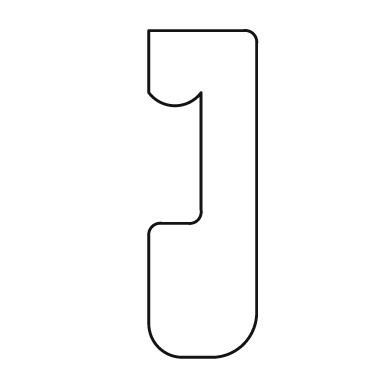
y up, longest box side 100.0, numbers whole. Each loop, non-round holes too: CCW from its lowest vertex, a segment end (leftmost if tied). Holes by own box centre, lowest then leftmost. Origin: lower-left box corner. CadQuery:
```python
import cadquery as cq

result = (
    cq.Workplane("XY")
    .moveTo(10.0, 0.0)
    .lineTo(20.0, 0.0)
    .threePointArc((29.0, 4.0), (33.0, 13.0))
    .lineTo(33.0, 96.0)
    .threePointArc((32.0, 99.0), (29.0, 100.0))
    .lineTo(0.0, 100.0)
    .lineTo(0.0, 81.0)
    .threePointArc((8.0, 77.0), (16.0, 81.0))
    .lineTo(16.0, 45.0)
    .threePointArc((15.0, 42.0), (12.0, 41.0))
    .lineTo(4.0, 41.0)
    .threePointArc((1.0, 40.0), (0.0, 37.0))
    .lineTo(0.0, 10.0)
    .threePointArc((3.0, 3.0), (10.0, 0.0))
    .close()
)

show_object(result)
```